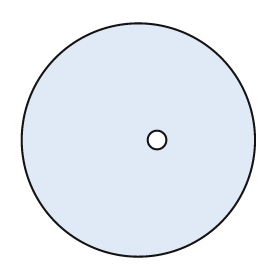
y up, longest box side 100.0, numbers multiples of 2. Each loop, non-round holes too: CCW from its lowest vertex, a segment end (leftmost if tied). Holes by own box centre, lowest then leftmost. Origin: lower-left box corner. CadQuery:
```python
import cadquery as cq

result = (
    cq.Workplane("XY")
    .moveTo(50.0, 50.0)
    .circle(50.0)
    .moveTo(58.0, 50.0)
    .circle(4.0)
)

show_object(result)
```